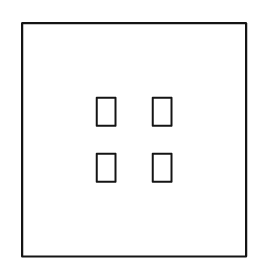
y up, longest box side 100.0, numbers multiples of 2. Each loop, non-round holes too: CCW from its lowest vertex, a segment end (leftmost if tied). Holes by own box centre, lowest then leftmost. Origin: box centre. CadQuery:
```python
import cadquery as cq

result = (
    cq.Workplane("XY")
    .moveTo(-48.0, -50.0)
    .lineTo(48.0, -50.0)
    .lineTo(48.0, 50.0)
    .lineTo(-48.0, 50.0)
    .close()
    .moveTo(-16.0, -18.0)
    .lineTo(-8.0, -18.0)
    .lineTo(-8.0, -6.0)
    .lineTo(-16.0, -6.0)
    .close()
    .moveTo(8.0, -18.0)
    .lineTo(16.0, -18.0)
    .lineTo(16.0, -6.0)
    .lineTo(8.0, -6.0)
    .close()
    .moveTo(-16.0, 6.0)
    .lineTo(-8.0, 6.0)
    .lineTo(-8.0, 18.0)
    .lineTo(-16.0, 18.0)
    .close()
    .moveTo(8.0, 6.0)
    .lineTo(16.0, 6.0)
    .lineTo(16.0, 18.0)
    .lineTo(8.0, 18.0)
    .close()
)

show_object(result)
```